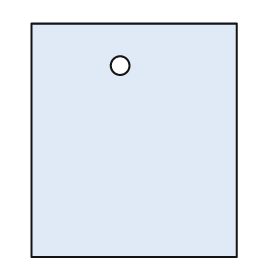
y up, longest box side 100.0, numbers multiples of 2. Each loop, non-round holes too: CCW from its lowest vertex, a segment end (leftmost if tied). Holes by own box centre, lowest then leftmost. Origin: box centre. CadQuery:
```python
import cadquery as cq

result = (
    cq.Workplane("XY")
    .moveTo(-44.0, -50.0)
    .lineTo(44.0, -50.0)
    .lineTo(44.0, 50.0)
    .lineTo(-44.0, 50.0)
    .close()
    .moveTo(-6.0, 32.0)
    .circle(4.0)
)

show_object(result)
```